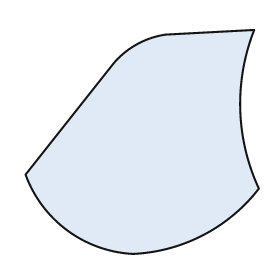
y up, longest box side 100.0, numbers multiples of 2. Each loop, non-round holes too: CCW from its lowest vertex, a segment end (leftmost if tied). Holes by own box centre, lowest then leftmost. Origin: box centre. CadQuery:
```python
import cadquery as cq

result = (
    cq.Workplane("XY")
    .moveTo(-4.0, -48.0)
    .threePointArc((26.0, -40.0), (50.0, -20.0))
    .threePointArc((42.0, 14.0), (48.0, 48.0))
    .lineTo(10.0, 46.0)
    .threePointArc((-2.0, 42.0), (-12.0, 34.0))
    .lineTo(-50.0, -14.0)
    .threePointArc((-32.0, -38.0), (-4.0, -48.0))
    .close()
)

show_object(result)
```